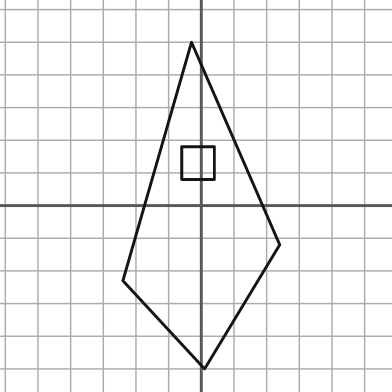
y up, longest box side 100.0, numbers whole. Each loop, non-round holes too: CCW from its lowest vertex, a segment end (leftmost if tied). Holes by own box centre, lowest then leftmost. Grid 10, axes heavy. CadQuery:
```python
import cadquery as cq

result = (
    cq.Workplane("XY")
    .moveTo(1.0, -50.0)
    .lineTo(24.0, -12.0)
    .lineTo(-3.0, 50.0)
    .lineTo(-24.0, -23.0)
    .close()
    .moveTo(-6.0, 8.0)
    .lineTo(4.0, 8.0)
    .lineTo(4.0, 18.0)
    .lineTo(-6.0, 18.0)
    .close()
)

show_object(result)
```